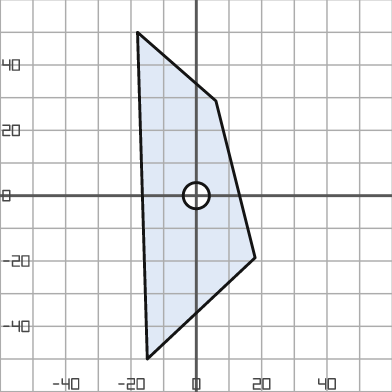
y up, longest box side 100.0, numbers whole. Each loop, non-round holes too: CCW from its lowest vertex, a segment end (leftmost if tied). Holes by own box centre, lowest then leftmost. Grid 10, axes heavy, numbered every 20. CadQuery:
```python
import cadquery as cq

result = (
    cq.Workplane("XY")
    .moveTo(-15.0, -50.0)
    .lineTo(18.0, -19.0)
    .lineTo(6.0, 29.0)
    .lineTo(-18.0, 50.0)
    .close()
    .moveTo(0.0, 0.0)
    .circle(4.0)
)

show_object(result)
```